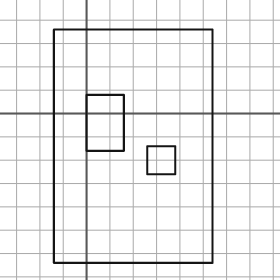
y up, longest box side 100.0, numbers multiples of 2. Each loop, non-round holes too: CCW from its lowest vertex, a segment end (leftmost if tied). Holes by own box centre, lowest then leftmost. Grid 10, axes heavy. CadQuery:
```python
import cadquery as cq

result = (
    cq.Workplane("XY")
    .moveTo(-14.0, -64.0)
    .lineTo(54.0, -64.0)
    .lineTo(54.0, 36.0)
    .lineTo(-14.0, 36.0)
    .close()
    .moveTo(26.0, -26.0)
    .lineTo(38.0, -26.0)
    .lineTo(38.0, -14.0)
    .lineTo(26.0, -14.0)
    .close()
    .moveTo(0.0, -16.0)
    .lineTo(16.0, -16.0)
    .lineTo(16.0, 8.0)
    .lineTo(0.0, 8.0)
    .close()
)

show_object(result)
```